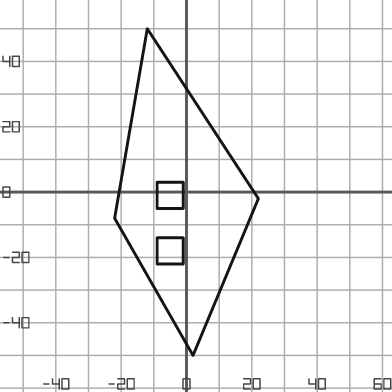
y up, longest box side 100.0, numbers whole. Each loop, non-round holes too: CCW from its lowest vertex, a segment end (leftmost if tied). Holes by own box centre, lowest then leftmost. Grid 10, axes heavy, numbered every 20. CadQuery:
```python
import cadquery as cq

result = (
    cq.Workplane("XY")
    .moveTo(2.0, -50.0)
    .lineTo(22.0, -2.0)
    .lineTo(-12.0, 50.0)
    .lineTo(-22.0, -8.0)
    .close()
    .moveTo(-9.0, -22.0)
    .lineTo(-1.0, -22.0)
    .lineTo(-1.0, -14.0)
    .lineTo(-9.0, -14.0)
    .close()
    .moveTo(-9.0, -5.0)
    .lineTo(-1.0, -5.0)
    .lineTo(-1.0, 3.0)
    .lineTo(-9.0, 3.0)
    .close()
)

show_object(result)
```